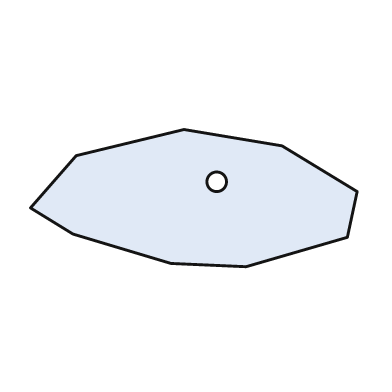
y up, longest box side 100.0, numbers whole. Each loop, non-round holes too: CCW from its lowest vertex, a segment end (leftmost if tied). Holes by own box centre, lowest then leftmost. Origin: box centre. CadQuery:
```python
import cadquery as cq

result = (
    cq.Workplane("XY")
    .moveTo(16.0, -21.0)
    .lineTo(47.0, -12.0)
    .lineTo(50.0, 2.0)
    .lineTo(27.0, 16.0)
    .lineTo(-3.0, 21.0)
    .lineTo(-36.0, 13.0)
    .lineTo(-50.0, -3.0)
    .lineTo(-37.0, -11.0)
    .lineTo(-7.0, -20.0)
    .close()
    .moveTo(7.0, 5.0)
    .circle(3.0)
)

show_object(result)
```